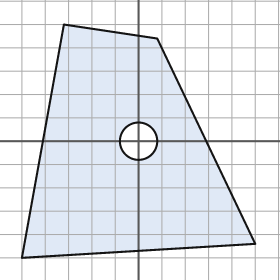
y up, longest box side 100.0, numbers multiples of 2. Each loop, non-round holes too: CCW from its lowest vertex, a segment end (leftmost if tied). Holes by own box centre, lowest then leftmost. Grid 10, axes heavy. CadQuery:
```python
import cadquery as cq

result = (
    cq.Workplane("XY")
    .moveTo(-50.0, -50.0)
    .lineTo(50.0, -44.0)
    .lineTo(8.0, 44.0)
    .lineTo(-32.0, 50.0)
    .close()
    .moveTo(0.0, 0.0)
    .circle(8.0)
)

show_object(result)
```